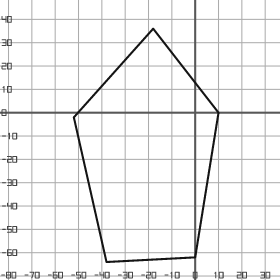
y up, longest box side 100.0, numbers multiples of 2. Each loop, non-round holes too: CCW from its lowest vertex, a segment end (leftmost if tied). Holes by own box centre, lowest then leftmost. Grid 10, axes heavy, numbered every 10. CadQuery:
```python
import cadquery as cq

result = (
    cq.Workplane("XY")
    .moveTo(-38.0, -64.0)
    .lineTo(0.0, -62.0)
    .lineTo(10.0, 0.0)
    .lineTo(-18.0, 36.0)
    .lineTo(-52.0, -2.0)
    .close()
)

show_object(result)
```